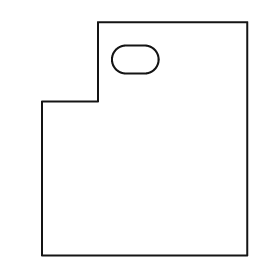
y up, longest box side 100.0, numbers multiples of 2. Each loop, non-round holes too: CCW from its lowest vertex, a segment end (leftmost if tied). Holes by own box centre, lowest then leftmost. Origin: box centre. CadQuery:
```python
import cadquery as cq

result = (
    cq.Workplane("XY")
    .moveTo(-44.0, -50.0)
    .lineTo(44.0, -50.0)
    .lineTo(44.0, 50.0)
    .lineTo(-20.0, 50.0)
    .lineTo(-20.0, 16.0)
    .lineTo(-44.0, 16.0)
    .close()
    .moveTo(-8.0, 28.0)
    .lineTo(0.0, 28.0)
    .threePointArc((6.0, 34.0), (0.0, 40.0))
    .lineTo(-8.0, 40.0)
    .threePointArc((-14.0, 34.0), (-8.0, 28.0))
    .close()
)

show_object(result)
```